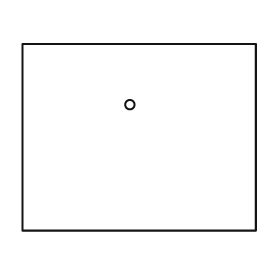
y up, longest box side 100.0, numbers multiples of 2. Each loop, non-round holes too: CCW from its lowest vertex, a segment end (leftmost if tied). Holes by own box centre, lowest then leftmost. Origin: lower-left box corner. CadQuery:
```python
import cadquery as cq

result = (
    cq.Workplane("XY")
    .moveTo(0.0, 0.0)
    .lineTo(100.0, 0.0)
    .lineTo(100.0, 80.0)
    .lineTo(0.0, 80.0)
    .close()
    .moveTo(46.0, 54.0)
    .circle(2.0)
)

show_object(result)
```